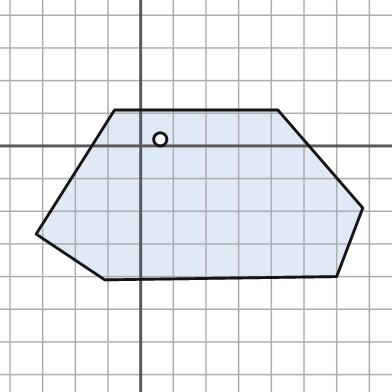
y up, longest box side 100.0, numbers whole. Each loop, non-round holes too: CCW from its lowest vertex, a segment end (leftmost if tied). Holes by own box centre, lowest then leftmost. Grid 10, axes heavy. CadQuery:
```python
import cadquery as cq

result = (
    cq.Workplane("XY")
    .moveTo(-11.0, -41.0)
    .lineTo(60.0, -40.0)
    .lineTo(68.0, -19.0)
    .lineTo(42.0, 11.0)
    .lineTo(-8.0, 11.0)
    .lineTo(-32.0, -27.0)
    .close()
    .moveTo(6.0, 2.0)
    .circle(2.0)
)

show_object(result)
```